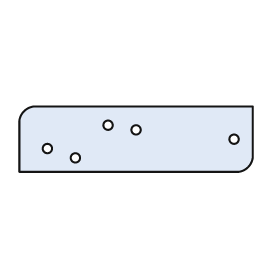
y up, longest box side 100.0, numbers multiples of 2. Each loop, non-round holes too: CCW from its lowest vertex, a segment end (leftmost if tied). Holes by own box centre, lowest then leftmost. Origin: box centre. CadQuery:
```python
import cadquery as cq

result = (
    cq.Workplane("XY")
    .moveTo(-50.0, -14.0)
    .lineTo(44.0, -14.0)
    .threePointArc((48.0, -12.0), (50.0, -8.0))
    .lineTo(50.0, 14.0)
    .lineTo(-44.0, 14.0)
    .threePointArc((-48.0, 12.0), (-50.0, 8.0))
    .close()
    .moveTo(-26.0, -8.0)
    .circle(2.0)
    .moveTo(-38.0, -4.0)
    .circle(2.0)
    .moveTo(42.0, 0.0)
    .circle(2.0)
    .moveTo(0.0, 4.0)
    .circle(2.0)
    .moveTo(-12.0, 6.0)
    .circle(2.0)
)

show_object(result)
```